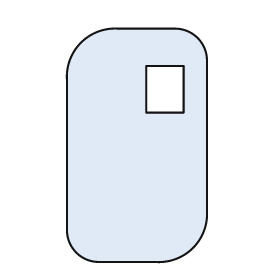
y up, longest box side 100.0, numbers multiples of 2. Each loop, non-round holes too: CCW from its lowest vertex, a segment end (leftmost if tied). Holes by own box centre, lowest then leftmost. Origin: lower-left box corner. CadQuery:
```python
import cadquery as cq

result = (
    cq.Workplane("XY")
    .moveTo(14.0, 0.0)
    .lineTo(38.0, 0.0)
    .threePointArc((54.0, 6.0), (60.0, 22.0))
    .lineTo(60.0, 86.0)
    .threePointArc((56.0, 96.0), (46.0, 100.0))
    .lineTo(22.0, 100.0)
    .threePointArc((6.0, 94.0), (0.0, 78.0))
    .lineTo(0.0, 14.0)
    .threePointArc((4.0, 4.0), (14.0, 0.0))
    .close()
    .moveTo(34.0, 64.0)
    .lineTo(50.0, 64.0)
    .lineTo(50.0, 84.0)
    .lineTo(34.0, 84.0)
    .close()
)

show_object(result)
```